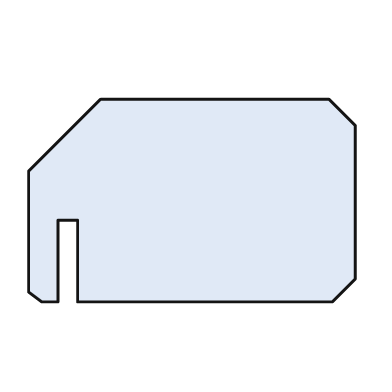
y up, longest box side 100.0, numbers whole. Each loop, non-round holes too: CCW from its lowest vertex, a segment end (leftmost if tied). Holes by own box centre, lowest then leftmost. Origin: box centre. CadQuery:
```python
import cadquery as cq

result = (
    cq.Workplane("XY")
    .moveTo(-46.0, -31.0)
    .lineTo(-41.0, -31.0)
    .lineTo(-41.0, -6.0)
    .lineTo(-35.0, -6.0)
    .lineTo(-35.0, -31.0)
    .lineTo(43.0, -31.0)
    .lineTo(50.0, -24.0)
    .lineTo(50.0, 23.0)
    .lineTo(42.0, 31.0)
    .lineTo(-28.0, 31.0)
    .lineTo(-50.0, 9.0)
    .lineTo(-50.0, -28.0)
    .close()
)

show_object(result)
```